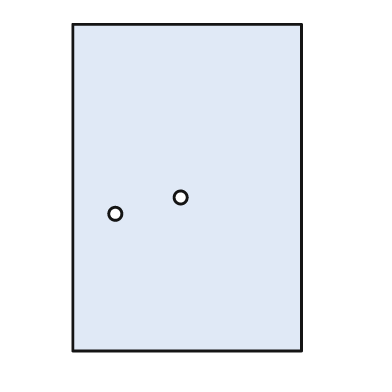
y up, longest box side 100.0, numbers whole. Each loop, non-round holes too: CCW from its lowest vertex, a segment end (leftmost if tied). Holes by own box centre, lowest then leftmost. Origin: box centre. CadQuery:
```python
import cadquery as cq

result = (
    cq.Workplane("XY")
    .moveTo(-35.0, -50.0)
    .lineTo(35.0, -50.0)
    .lineTo(35.0, 50.0)
    .lineTo(-35.0, 50.0)
    .close()
    .moveTo(-22.0, -8.0)
    .circle(2.0)
    .moveTo(-2.0, -3.0)
    .circle(2.0)
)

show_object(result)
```